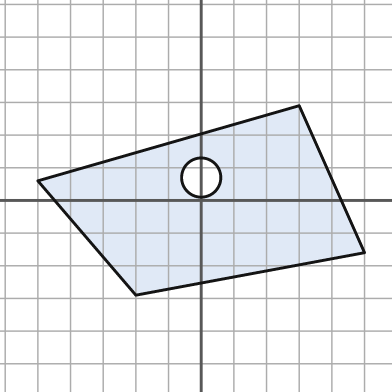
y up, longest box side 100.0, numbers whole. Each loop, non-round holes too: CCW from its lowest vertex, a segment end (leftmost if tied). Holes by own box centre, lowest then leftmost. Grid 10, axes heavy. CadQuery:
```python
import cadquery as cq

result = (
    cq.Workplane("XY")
    .moveTo(-20.0, -29.0)
    .lineTo(50.0, -16.0)
    .lineTo(30.0, 29.0)
    .lineTo(-50.0, 6.0)
    .close()
    .moveTo(0.0, 7.0)
    .circle(6.0)
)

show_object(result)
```